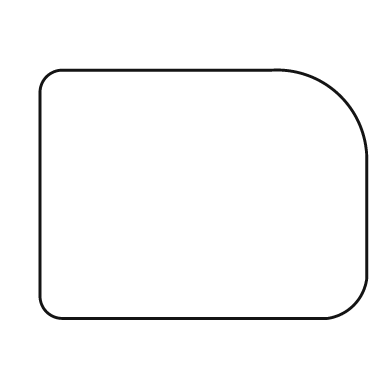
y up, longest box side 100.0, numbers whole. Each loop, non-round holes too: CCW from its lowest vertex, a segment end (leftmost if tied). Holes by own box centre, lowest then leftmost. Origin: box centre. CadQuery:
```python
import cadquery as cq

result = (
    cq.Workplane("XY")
    .moveTo(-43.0, -38.0)
    .lineTo(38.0, -38.0)
    .threePointArc((46.0, -34.0), (50.0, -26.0))
    .lineTo(50.0, 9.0)
    .threePointArc((42.0, 30.0), (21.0, 38.0))
    .lineTo(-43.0, 38.0)
    .threePointArc((-48.0, 36.0), (-50.0, 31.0))
    .lineTo(-50.0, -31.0)
    .threePointArc((-48.0, -36.0), (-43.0, -38.0))
    .close()
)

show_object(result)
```